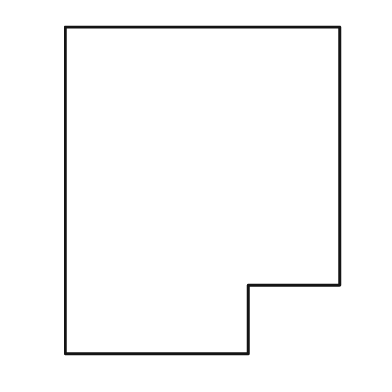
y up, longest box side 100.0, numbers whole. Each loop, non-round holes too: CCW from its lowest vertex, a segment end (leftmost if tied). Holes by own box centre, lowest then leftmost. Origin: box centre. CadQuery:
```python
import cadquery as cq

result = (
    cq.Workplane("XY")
    .moveTo(-42.0, -50.0)
    .lineTo(14.0, -50.0)
    .lineTo(14.0, -29.0)
    .lineTo(42.0, -29.0)
    .lineTo(42.0, 50.0)
    .lineTo(-42.0, 50.0)
    .close()
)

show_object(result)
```